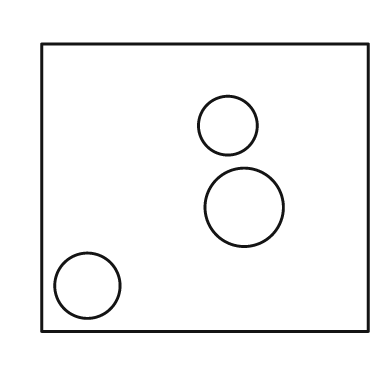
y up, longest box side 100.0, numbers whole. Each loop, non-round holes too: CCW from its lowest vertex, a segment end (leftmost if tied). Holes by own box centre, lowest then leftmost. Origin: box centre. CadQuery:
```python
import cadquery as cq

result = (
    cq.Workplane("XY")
    .moveTo(-50.0, -44.0)
    .lineTo(50.0, -44.0)
    .lineTo(50.0, 44.0)
    .lineTo(-50.0, 44.0)
    .close()
    .moveTo(-36.0, -30.0)
    .circle(10.0)
    .moveTo(12.0, -6.0)
    .circle(12.0)
    .moveTo(7.0, 19.0)
    .circle(9.0)
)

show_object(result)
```